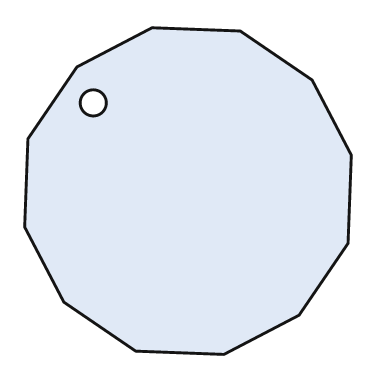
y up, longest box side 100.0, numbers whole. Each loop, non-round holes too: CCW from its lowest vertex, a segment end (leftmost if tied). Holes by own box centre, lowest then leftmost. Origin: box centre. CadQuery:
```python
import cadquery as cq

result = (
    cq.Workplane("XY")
    .moveTo(11.0, -50.0)
    .lineTo(34.0, -38.0)
    .lineTo(49.0, -16.0)
    .lineTo(50.0, 11.0)
    .lineTo(38.0, 34.0)
    .lineTo(16.0, 49.0)
    .lineTo(-11.0, 50.0)
    .lineTo(-34.0, 38.0)
    .lineTo(-49.0, 16.0)
    .lineTo(-50.0, -11.0)
    .lineTo(-38.0, -34.0)
    .lineTo(-16.0, -49.0)
    .close()
    .moveTo(-29.0, 27.0)
    .circle(4.0)
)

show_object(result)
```